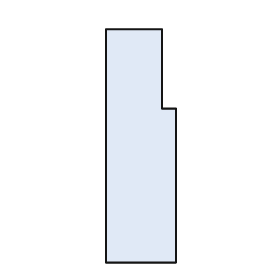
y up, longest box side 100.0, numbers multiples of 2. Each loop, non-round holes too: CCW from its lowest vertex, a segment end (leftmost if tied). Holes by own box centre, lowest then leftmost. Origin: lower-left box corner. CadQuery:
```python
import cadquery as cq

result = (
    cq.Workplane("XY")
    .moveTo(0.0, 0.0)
    .lineTo(30.0, 0.0)
    .lineTo(30.0, 66.0)
    .lineTo(24.0, 66.0)
    .lineTo(24.0, 100.0)
    .lineTo(0.0, 100.0)
    .close()
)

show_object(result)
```